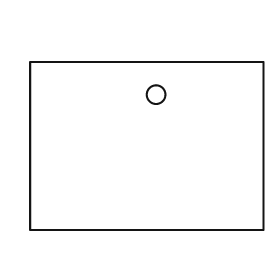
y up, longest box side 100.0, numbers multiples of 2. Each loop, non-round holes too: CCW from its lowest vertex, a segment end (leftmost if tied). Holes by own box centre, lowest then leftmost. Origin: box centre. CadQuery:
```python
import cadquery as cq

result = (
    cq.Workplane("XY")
    .moveTo(-50.0, -36.0)
    .lineTo(50.0, -36.0)
    .lineTo(50.0, 36.0)
    .lineTo(-50.0, 36.0)
    .close()
    .moveTo(4.0, 22.0)
    .circle(4.0)
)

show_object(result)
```